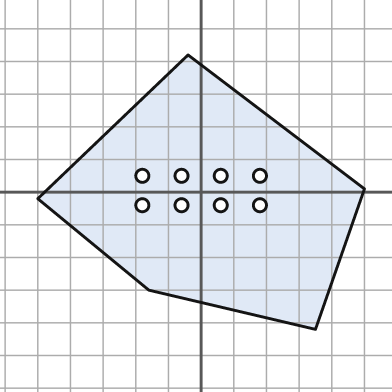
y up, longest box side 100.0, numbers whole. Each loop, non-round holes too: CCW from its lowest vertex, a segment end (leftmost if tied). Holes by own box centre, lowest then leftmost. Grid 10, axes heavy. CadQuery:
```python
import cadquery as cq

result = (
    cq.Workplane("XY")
    .moveTo(35.0, -42.0)
    .lineTo(50.0, 1.0)
    .lineTo(-4.0, 42.0)
    .lineTo(-50.0, -2.0)
    .lineTo(-16.0, -30.0)
    .close()
    .moveTo(-18.0, -4.0)
    .circle(2.0)
    .moveTo(-6.0, -4.0)
    .circle(2.0)
    .moveTo(6.0, -4.0)
    .circle(2.0)
    .moveTo(18.0, -4.0)
    .circle(2.0)
    .moveTo(-18.0, 5.0)
    .circle(2.0)
    .moveTo(-6.0, 5.0)
    .circle(2.0)
    .moveTo(6.0, 5.0)
    .circle(2.0)
    .moveTo(18.0, 5.0)
    .circle(2.0)
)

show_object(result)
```